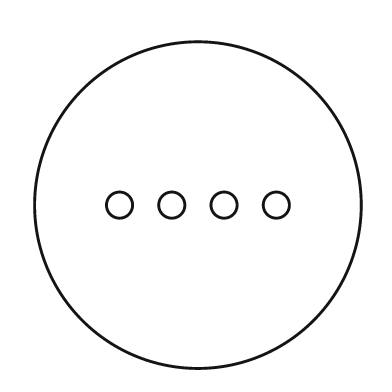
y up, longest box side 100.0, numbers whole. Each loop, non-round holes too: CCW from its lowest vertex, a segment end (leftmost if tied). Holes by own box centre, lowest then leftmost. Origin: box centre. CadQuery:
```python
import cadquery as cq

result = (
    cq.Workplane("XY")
    .moveTo(0.0, 0.0)
    .circle(50.0)
    .moveTo(-24.0, 0.0)
    .circle(4.0)
    .moveTo(-8.0, 0.0)
    .circle(4.0)
    .moveTo(8.0, 0.0)
    .circle(4.0)
    .moveTo(24.0, 0.0)
    .circle(4.0)
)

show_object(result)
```